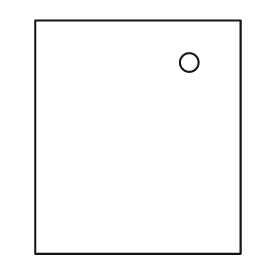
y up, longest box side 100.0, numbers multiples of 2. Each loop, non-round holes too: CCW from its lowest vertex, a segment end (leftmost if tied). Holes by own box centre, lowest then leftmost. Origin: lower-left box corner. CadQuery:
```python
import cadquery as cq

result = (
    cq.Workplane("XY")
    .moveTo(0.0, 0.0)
    .lineTo(88.0, 0.0)
    .lineTo(88.0, 100.0)
    .lineTo(0.0, 100.0)
    .close()
    .moveTo(66.0, 82.0)
    .circle(4.0)
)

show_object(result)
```